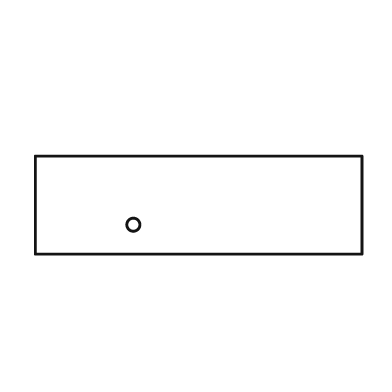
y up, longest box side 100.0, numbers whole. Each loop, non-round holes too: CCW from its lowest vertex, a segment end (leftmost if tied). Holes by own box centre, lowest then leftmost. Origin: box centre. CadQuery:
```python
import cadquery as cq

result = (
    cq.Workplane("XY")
    .moveTo(-50.0, -15.0)
    .lineTo(50.0, -15.0)
    .lineTo(50.0, 15.0)
    .lineTo(-50.0, 15.0)
    .close()
    .moveTo(-20.0, -6.0)
    .circle(2.0)
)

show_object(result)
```